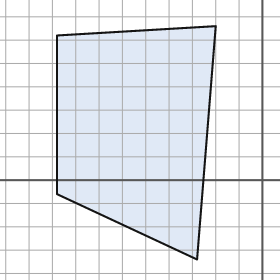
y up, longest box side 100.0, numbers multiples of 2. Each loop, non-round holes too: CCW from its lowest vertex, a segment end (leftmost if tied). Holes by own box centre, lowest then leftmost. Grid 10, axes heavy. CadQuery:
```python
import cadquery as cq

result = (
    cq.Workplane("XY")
    .moveTo(-28.0, -34.0)
    .lineTo(-20.0, 66.0)
    .lineTo(-88.0, 62.0)
    .lineTo(-88.0, -6.0)
    .close()
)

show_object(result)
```